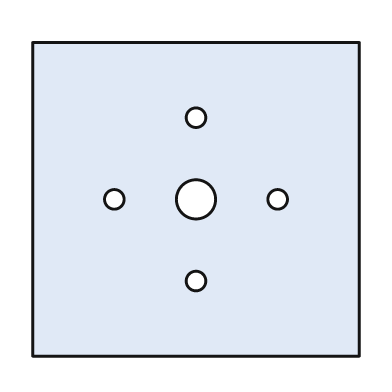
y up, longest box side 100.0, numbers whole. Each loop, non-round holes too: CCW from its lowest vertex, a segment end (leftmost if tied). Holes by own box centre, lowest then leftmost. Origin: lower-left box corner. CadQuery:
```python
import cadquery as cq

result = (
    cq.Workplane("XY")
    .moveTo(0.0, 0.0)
    .lineTo(100.0, 0.0)
    .lineTo(100.0, 96.0)
    .lineTo(0.0, 96.0)
    .close()
    .moveTo(50.0, 23.0)
    .circle(3.0)
    .moveTo(25.0, 48.0)
    .circle(3.0)
    .moveTo(50.0, 48.0)
    .circle(6.0)
    .moveTo(75.0, 48.0)
    .circle(3.0)
    .moveTo(50.0, 73.0)
    .circle(3.0)
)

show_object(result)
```